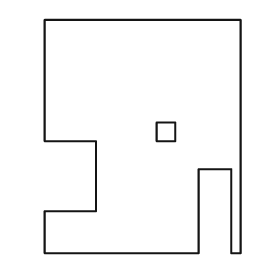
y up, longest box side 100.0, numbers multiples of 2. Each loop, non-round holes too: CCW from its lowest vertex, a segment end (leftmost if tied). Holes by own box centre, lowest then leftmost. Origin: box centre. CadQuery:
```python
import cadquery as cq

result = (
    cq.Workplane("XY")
    .moveTo(-42.0, -50.0)
    .lineTo(24.0, -50.0)
    .lineTo(24.0, -14.0)
    .lineTo(38.0, -14.0)
    .lineTo(38.0, -50.0)
    .lineTo(42.0, -50.0)
    .lineTo(42.0, 50.0)
    .lineTo(-42.0, 50.0)
    .lineTo(-42.0, -2.0)
    .lineTo(-20.0, -2.0)
    .lineTo(-20.0, -32.0)
    .lineTo(-42.0, -32.0)
    .close()
    .moveTo(6.0, -2.0)
    .lineTo(14.0, -2.0)
    .lineTo(14.0, 6.0)
    .lineTo(6.0, 6.0)
    .close()
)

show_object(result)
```